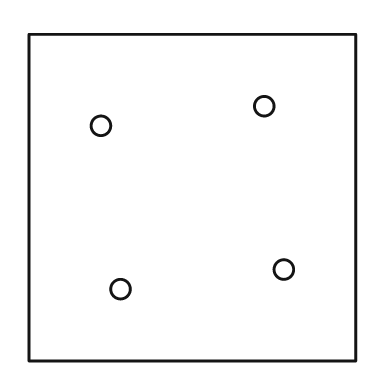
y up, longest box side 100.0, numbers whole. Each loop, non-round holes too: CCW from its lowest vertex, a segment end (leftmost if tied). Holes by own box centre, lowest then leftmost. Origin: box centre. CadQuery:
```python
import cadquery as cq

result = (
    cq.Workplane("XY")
    .moveTo(-50.0, -50.0)
    .lineTo(50.0, -50.0)
    .lineTo(50.0, 50.0)
    .lineTo(-50.0, 50.0)
    .close()
    .moveTo(-22.0, -28.0)
    .circle(3.0)
    .moveTo(28.0, -22.0)
    .circle(3.0)
    .moveTo(-28.0, 22.0)
    .circle(3.0)
    .moveTo(22.0, 28.0)
    .circle(3.0)
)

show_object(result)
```